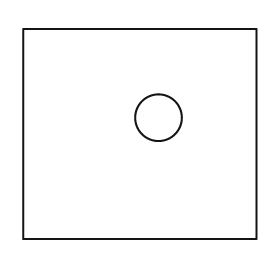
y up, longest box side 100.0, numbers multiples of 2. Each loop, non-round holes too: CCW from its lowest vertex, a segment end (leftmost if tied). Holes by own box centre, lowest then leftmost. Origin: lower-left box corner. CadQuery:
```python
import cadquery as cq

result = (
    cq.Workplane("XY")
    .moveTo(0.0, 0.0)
    .lineTo(100.0, 0.0)
    .lineTo(100.0, 90.0)
    .lineTo(0.0, 90.0)
    .close()
    .moveTo(58.0, 52.0)
    .circle(10.0)
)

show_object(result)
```